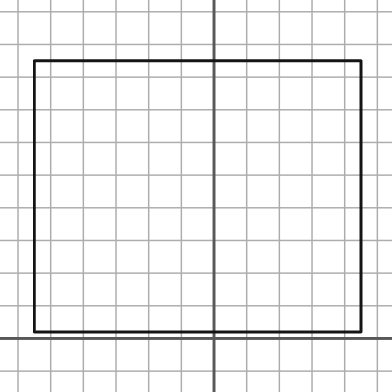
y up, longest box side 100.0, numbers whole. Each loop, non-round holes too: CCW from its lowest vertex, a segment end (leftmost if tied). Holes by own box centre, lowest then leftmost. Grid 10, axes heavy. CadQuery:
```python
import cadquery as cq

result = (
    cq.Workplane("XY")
    .moveTo(-55.0, 2.0)
    .lineTo(45.0, 2.0)
    .lineTo(45.0, 85.0)
    .lineTo(-55.0, 85.0)
    .close()
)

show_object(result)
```